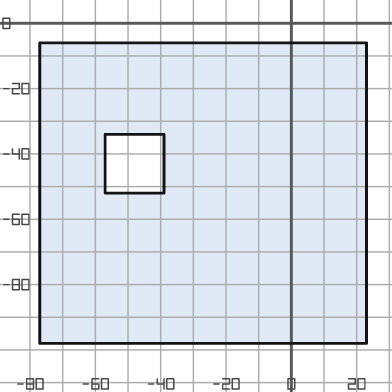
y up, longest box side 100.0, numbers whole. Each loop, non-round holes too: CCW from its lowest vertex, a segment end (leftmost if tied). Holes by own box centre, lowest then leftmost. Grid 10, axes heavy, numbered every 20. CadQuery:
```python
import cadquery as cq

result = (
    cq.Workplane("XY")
    .moveTo(-77.0, -98.0)
    .lineTo(23.0, -98.0)
    .lineTo(23.0, -6.0)
    .lineTo(-77.0, -6.0)
    .close()
    .moveTo(-57.0, -52.0)
    .lineTo(-39.0, -52.0)
    .lineTo(-39.0, -34.0)
    .lineTo(-57.0, -34.0)
    .close()
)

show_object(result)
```